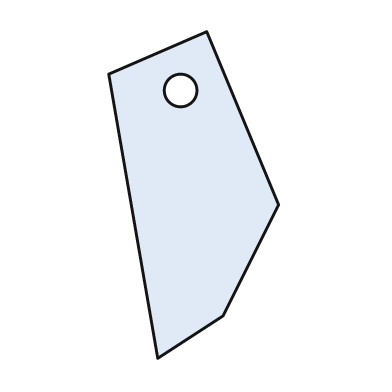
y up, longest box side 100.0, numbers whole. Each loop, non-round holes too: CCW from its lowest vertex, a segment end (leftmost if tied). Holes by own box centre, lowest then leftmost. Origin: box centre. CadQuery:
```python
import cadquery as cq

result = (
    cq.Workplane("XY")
    .moveTo(-11.0, -50.0)
    .lineTo(9.0, -37.0)
    .lineTo(26.0, -3.0)
    .lineTo(4.0, 50.0)
    .lineTo(-26.0, 37.0)
    .close()
    .moveTo(-4.0, 32.0)
    .circle(5.0)
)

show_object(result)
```